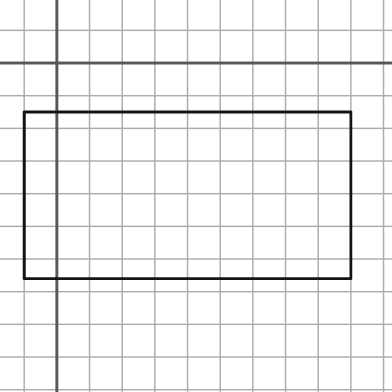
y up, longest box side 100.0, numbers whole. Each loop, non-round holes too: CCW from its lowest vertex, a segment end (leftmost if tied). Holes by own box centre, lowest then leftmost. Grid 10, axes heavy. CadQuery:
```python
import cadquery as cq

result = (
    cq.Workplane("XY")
    .moveTo(-10.0, -66.0)
    .lineTo(90.0, -66.0)
    .lineTo(90.0, -15.0)
    .lineTo(-10.0, -15.0)
    .close()
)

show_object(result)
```